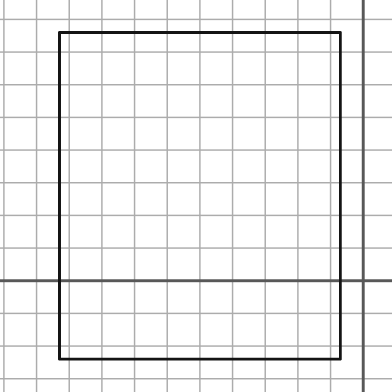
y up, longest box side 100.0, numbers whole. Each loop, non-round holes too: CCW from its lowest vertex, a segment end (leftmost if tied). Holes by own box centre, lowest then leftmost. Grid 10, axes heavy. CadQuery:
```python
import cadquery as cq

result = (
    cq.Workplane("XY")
    .moveTo(-93.0, -24.0)
    .lineTo(-7.0, -24.0)
    .lineTo(-7.0, 76.0)
    .lineTo(-93.0, 76.0)
    .close()
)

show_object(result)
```